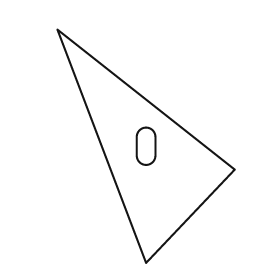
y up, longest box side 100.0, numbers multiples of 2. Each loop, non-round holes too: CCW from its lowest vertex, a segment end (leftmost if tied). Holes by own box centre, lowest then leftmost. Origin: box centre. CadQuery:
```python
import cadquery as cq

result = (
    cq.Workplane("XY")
    .moveTo(0.0, -50.0)
    .lineTo(38.0, -10.0)
    .lineTo(-38.0, 50.0)
    .close()
    .moveTo(-4.0, -4.0)
    .threePointArc((0.0, -8.0), (4.0, -4.0))
    .lineTo(4.0, 4.0)
    .threePointArc((0.0, 8.0), (-4.0, 4.0))
    .close()
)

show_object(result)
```